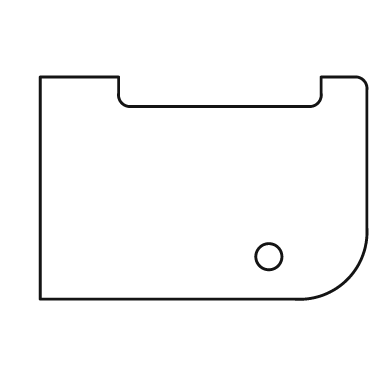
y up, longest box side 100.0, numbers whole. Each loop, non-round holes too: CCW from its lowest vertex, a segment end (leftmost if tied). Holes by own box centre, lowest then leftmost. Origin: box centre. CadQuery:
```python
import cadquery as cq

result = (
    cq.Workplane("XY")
    .moveTo(-50.0, -34.0)
    .lineTo(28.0, -34.0)
    .threePointArc((44.0, -28.0), (50.0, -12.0))
    .lineTo(50.0, 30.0)
    .threePointArc((49.0, 33.0), (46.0, 34.0))
    .lineTo(36.0, 34.0)
    .lineTo(36.0, 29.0)
    .threePointArc((35.0, 26.0), (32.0, 25.0))
    .lineTo(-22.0, 25.0)
    .threePointArc((-25.0, 26.0), (-26.0, 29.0))
    .lineTo(-26.0, 34.0)
    .lineTo(-50.0, 34.0)
    .close()
    .moveTo(20.0, -21.0)
    .circle(4.0)
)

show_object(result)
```